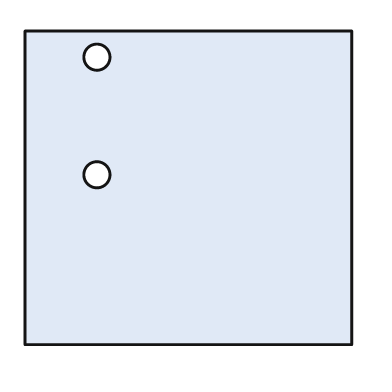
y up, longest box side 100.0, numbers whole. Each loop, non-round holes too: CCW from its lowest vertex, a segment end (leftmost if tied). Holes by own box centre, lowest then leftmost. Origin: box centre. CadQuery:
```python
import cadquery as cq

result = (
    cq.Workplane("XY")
    .moveTo(-50.0, -48.0)
    .lineTo(50.0, -48.0)
    .lineTo(50.0, 48.0)
    .lineTo(-50.0, 48.0)
    .close()
    .moveTo(-28.0, 4.0)
    .circle(4.0)
    .moveTo(-28.0, 40.0)
    .circle(4.0)
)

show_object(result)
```